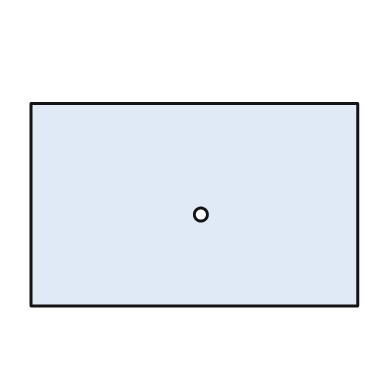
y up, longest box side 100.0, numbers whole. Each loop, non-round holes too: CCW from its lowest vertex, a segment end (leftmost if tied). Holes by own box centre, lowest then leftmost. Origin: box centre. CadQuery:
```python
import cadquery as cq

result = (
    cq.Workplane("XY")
    .moveTo(-50.0, -31.0)
    .lineTo(50.0, -31.0)
    .lineTo(50.0, 31.0)
    .lineTo(-50.0, 31.0)
    .close()
    .moveTo(2.0, -3.0)
    .circle(2.0)
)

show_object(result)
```